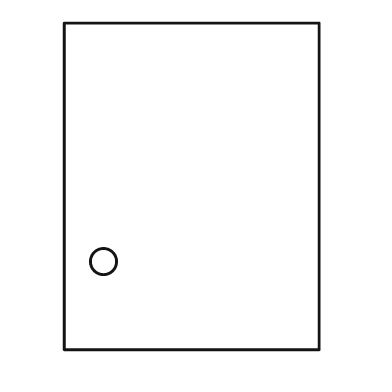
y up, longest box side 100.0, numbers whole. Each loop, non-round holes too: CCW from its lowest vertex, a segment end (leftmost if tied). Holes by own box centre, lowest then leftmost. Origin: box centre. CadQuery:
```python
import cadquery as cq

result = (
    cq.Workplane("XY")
    .moveTo(-39.0, -50.0)
    .lineTo(39.0, -50.0)
    .lineTo(39.0, 50.0)
    .lineTo(-39.0, 50.0)
    .close()
    .moveTo(-27.0, -23.0)
    .circle(4.0)
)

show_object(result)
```